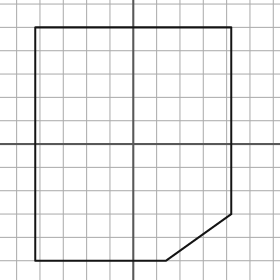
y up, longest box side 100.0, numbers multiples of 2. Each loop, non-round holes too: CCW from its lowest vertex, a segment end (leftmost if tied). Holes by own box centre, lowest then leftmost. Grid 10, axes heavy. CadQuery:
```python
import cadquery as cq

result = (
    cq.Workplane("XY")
    .moveTo(-42.0, -50.0)
    .lineTo(14.0, -50.0)
    .lineTo(42.0, -30.0)
    .lineTo(42.0, 50.0)
    .lineTo(-42.0, 50.0)
    .close()
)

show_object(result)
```